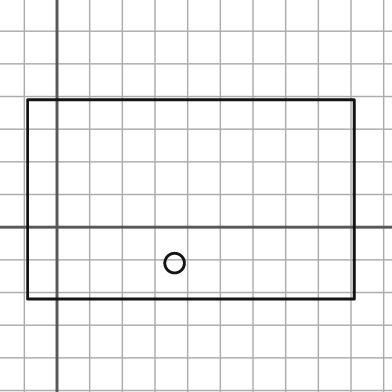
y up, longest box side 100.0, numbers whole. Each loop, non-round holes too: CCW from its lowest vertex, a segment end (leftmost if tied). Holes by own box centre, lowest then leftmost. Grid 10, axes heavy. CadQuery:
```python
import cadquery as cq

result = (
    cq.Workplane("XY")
    .moveTo(-9.0, -22.0)
    .lineTo(91.0, -22.0)
    .lineTo(91.0, 39.0)
    .lineTo(-9.0, 39.0)
    .close()
    .moveTo(36.0, -11.0)
    .circle(3.0)
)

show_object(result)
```